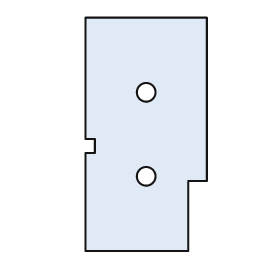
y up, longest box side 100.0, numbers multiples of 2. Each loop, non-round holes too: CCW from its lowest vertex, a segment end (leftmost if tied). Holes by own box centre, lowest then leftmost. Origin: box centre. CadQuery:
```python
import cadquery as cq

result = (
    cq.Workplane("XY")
    .moveTo(-26.0, -50.0)
    .lineTo(18.0, -50.0)
    .lineTo(18.0, -20.0)
    .lineTo(26.0, -20.0)
    .lineTo(26.0, 50.0)
    .lineTo(-26.0, 50.0)
    .lineTo(-26.0, -2.0)
    .lineTo(-22.0, -2.0)
    .lineTo(-22.0, -8.0)
    .lineTo(-26.0, -8.0)
    .close()
    .moveTo(0.0, -18.0)
    .circle(4.0)
    .moveTo(0.0, 18.0)
    .circle(4.0)
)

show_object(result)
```